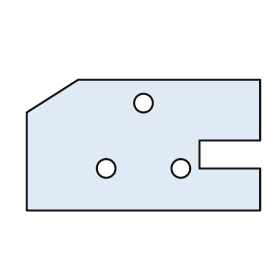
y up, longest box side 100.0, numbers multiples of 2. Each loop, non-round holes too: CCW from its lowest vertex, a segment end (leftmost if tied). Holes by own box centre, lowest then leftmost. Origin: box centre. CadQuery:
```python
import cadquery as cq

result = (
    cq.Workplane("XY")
    .moveTo(-50.0, -28.0)
    .lineTo(50.0, -28.0)
    .lineTo(50.0, -10.0)
    .lineTo(24.0, -10.0)
    .lineTo(24.0, 2.0)
    .lineTo(50.0, 2.0)
    .lineTo(50.0, 28.0)
    .lineTo(-28.0, 28.0)
    .lineTo(-50.0, 14.0)
    .close()
    .moveTo(-16.0, -10.0)
    .circle(4.0)
    .moveTo(16.0, -10.0)
    .circle(4.0)
    .moveTo(0.0, 18.0)
    .circle(4.0)
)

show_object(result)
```